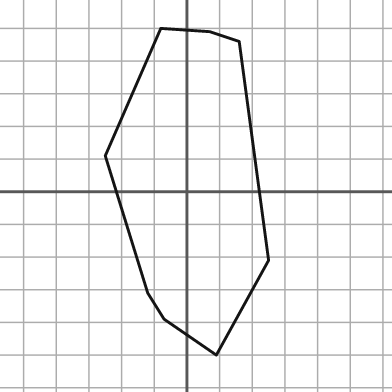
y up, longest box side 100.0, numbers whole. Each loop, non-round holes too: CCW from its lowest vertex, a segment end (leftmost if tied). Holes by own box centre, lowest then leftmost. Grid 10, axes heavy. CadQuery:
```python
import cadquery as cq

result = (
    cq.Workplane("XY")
    .moveTo(9.0, -50.0)
    .lineTo(25.0, -21.0)
    .lineTo(16.0, 46.0)
    .lineTo(7.0, 49.0)
    .lineTo(-8.0, 50.0)
    .lineTo(-25.0, 11.0)
    .lineTo(-12.0, -31.0)
    .lineTo(-7.0, -39.0)
    .close()
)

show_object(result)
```